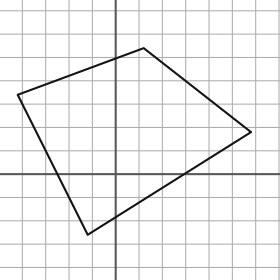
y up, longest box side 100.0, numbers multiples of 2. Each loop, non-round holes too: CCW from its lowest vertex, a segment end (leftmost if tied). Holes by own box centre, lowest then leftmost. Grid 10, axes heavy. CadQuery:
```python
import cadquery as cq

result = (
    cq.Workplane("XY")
    .moveTo(-12.0, -26.0)
    .lineTo(58.0, 18.0)
    .lineTo(12.0, 54.0)
    .lineTo(-42.0, 34.0)
    .close()
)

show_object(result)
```